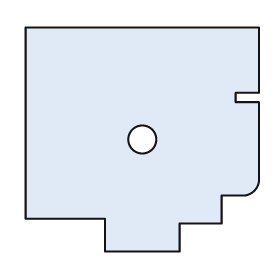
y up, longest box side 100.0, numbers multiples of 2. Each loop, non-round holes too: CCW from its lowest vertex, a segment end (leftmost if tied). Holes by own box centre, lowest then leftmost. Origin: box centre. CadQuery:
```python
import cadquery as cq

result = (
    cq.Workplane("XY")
    .moveTo(-16.0, -48.0)
    .lineTo(16.0, -48.0)
    .lineTo(16.0, -36.0)
    .lineTo(34.0, -36.0)
    .lineTo(34.0, -24.0)
    .lineTo(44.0, -24.0)
    .threePointArc((48.0, -22.0), (50.0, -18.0))
    .lineTo(50.0, 16.0)
    .lineTo(40.0, 16.0)
    .lineTo(40.0, 20.0)
    .lineTo(50.0, 20.0)
    .lineTo(50.0, 48.0)
    .lineTo(-50.0, 48.0)
    .lineTo(-50.0, -34.0)
    .lineTo(-16.0, -34.0)
    .close()
    .moveTo(0.0, 0.0)
    .circle(6.0)
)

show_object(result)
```